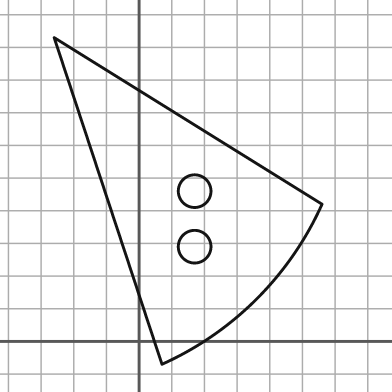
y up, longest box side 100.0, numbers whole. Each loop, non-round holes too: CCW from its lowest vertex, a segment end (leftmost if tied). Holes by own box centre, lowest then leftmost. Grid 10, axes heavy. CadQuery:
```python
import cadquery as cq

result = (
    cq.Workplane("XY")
    .moveTo(7.0, -7.0)
    .threePointArc((36.0, 13.0), (56.0, 42.0))
    .lineTo(-26.0, 93.0)
    .close()
    .moveTo(17.0, 29.0)
    .circle(5.0)
    .moveTo(17.0, 46.0)
    .circle(5.0)
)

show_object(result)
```